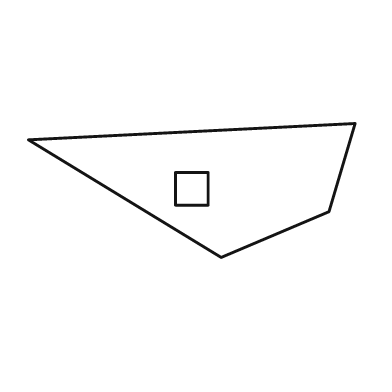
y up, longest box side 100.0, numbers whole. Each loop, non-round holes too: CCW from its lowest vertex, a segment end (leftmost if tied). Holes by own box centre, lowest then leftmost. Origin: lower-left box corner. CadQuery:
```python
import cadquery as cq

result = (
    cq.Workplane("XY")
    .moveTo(59.0, 0.0)
    .lineTo(92.0, 14.0)
    .lineTo(100.0, 41.0)
    .lineTo(0.0, 36.0)
    .close()
    .moveTo(45.0, 16.0)
    .lineTo(55.0, 16.0)
    .lineTo(55.0, 26.0)
    .lineTo(45.0, 26.0)
    .close()
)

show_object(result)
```